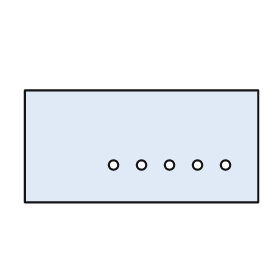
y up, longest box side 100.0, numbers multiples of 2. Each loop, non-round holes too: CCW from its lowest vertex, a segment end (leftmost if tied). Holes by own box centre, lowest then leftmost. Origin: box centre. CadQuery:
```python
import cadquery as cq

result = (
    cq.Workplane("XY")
    .moveTo(-50.0, -24.0)
    .lineTo(50.0, -24.0)
    .lineTo(50.0, 24.0)
    .lineTo(-50.0, 24.0)
    .close()
    .moveTo(-12.0, -8.0)
    .circle(2.0)
    .moveTo(0.0, -8.0)
    .circle(2.0)
    .moveTo(12.0, -8.0)
    .circle(2.0)
    .moveTo(24.0, -8.0)
    .circle(2.0)
    .moveTo(36.0, -8.0)
    .circle(2.0)
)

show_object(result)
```